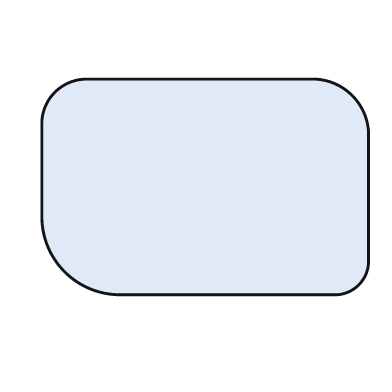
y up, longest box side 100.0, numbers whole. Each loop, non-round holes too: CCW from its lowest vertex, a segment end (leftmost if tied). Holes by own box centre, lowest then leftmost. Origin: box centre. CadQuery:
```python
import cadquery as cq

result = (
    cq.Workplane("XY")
    .moveTo(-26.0, -33.0)
    .lineTo(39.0, -33.0)
    .threePointArc((47.0, -30.0), (50.0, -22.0))
    .lineTo(50.0, 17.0)
    .threePointArc((45.0, 28.0), (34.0, 33.0))
    .lineTo(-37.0, 33.0)
    .threePointArc((-46.0, 29.0), (-50.0, 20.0))
    .lineTo(-50.0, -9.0)
    .threePointArc((-43.0, -26.0), (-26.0, -33.0))
    .close()
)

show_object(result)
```